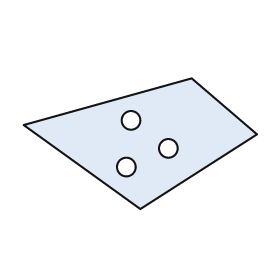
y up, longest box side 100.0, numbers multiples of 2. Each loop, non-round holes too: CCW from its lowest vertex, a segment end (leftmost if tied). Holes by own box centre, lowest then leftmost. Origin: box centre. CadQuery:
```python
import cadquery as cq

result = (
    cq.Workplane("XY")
    .moveTo(0.0, -28.0)
    .lineTo(50.0, 4.0)
    .lineTo(22.0, 28.0)
    .lineTo(-50.0, 8.0)
    .close()
    .moveTo(-6.0, -10.0)
    .circle(4.0)
    .moveTo(12.0, -2.0)
    .circle(4.0)
    .moveTo(-4.0, 10.0)
    .circle(4.0)
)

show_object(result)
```